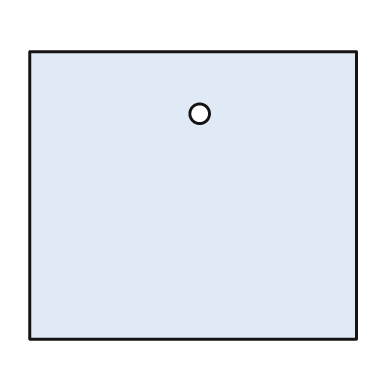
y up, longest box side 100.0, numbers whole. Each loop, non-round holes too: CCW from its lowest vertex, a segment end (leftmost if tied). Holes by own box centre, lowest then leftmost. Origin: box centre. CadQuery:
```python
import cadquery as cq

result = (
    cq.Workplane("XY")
    .moveTo(-50.0, -44.0)
    .lineTo(50.0, -44.0)
    .lineTo(50.0, 44.0)
    .lineTo(-50.0, 44.0)
    .close()
    .moveTo(2.0, 25.0)
    .circle(3.0)
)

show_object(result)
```